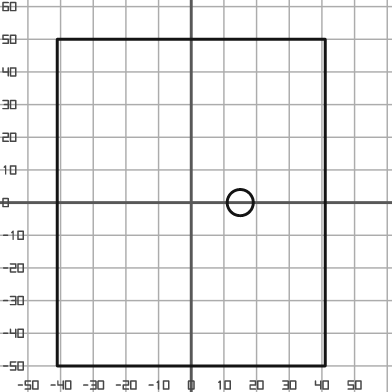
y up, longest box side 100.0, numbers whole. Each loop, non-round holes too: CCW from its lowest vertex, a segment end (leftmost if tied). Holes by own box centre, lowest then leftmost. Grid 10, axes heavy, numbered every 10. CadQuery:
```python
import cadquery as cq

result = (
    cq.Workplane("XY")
    .moveTo(-41.0, -50.0)
    .lineTo(41.0, -50.0)
    .lineTo(41.0, 50.0)
    .lineTo(-41.0, 50.0)
    .close()
    .moveTo(15.0, 0.0)
    .circle(4.0)
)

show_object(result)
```